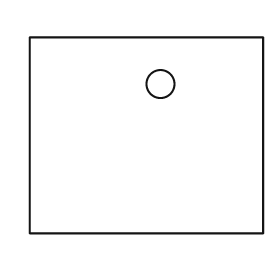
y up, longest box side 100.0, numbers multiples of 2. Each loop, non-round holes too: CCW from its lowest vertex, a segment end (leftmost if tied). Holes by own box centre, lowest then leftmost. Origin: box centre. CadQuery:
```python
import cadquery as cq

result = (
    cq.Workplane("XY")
    .moveTo(-50.0, -42.0)
    .lineTo(50.0, -42.0)
    .lineTo(50.0, 42.0)
    .lineTo(-50.0, 42.0)
    .close()
    .moveTo(6.0, 22.0)
    .circle(6.0)
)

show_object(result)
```